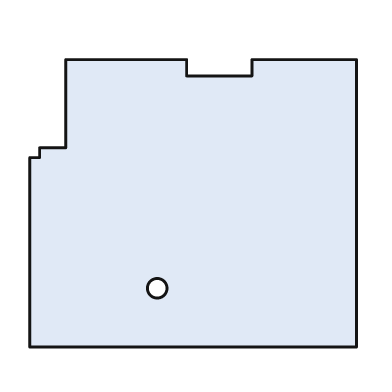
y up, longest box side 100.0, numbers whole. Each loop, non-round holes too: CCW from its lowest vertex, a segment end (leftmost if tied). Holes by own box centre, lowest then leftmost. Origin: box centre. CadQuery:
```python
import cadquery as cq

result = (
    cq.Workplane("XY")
    .moveTo(-50.0, -44.0)
    .lineTo(50.0, -44.0)
    .lineTo(50.0, 44.0)
    .lineTo(18.0, 44.0)
    .lineTo(18.0, 39.0)
    .lineTo(-2.0, 39.0)
    .lineTo(-2.0, 44.0)
    .lineTo(-39.0, 44.0)
    .lineTo(-39.0, 17.0)
    .lineTo(-47.0, 17.0)
    .lineTo(-47.0, 14.0)
    .lineTo(-50.0, 14.0)
    .close()
    .moveTo(-11.0, -26.0)
    .circle(3.0)
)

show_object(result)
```